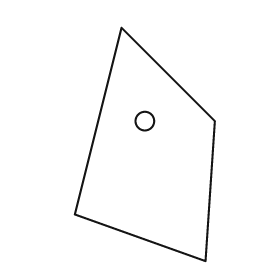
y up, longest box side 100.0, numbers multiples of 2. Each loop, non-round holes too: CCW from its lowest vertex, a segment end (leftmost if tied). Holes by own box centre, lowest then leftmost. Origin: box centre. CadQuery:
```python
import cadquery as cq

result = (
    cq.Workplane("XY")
    .moveTo(26.0, -50.0)
    .lineTo(30.0, 10.0)
    .lineTo(-10.0, 50.0)
    .lineTo(-30.0, -30.0)
    .close()
    .moveTo(0.0, 10.0)
    .circle(4.0)
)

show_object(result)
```